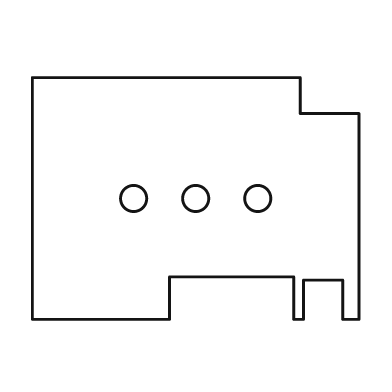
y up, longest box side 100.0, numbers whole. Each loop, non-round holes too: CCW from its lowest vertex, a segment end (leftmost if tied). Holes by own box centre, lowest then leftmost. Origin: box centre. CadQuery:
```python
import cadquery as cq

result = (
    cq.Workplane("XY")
    .moveTo(-50.0, -37.0)
    .lineTo(-8.0, -37.0)
    .lineTo(-8.0, -24.0)
    .lineTo(30.0, -24.0)
    .lineTo(30.0, -37.0)
    .lineTo(33.0, -37.0)
    .lineTo(33.0, -25.0)
    .lineTo(45.0, -25.0)
    .lineTo(45.0, -37.0)
    .lineTo(50.0, -37.0)
    .lineTo(50.0, 26.0)
    .lineTo(32.0, 26.0)
    .lineTo(32.0, 37.0)
    .lineTo(-50.0, 37.0)
    .close()
    .moveTo(-19.0, 0.0)
    .circle(4.0)
    .moveTo(0.0, 0.0)
    .circle(4.0)
    .moveTo(19.0, 0.0)
    .circle(4.0)
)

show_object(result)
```